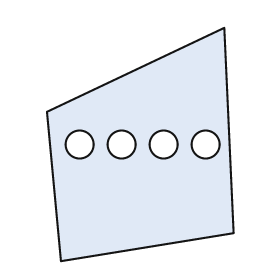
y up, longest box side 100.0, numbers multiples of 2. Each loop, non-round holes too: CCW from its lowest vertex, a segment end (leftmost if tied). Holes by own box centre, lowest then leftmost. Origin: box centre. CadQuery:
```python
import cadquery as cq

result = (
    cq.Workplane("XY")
    .moveTo(-34.0, -50.0)
    .lineTo(40.0, -38.0)
    .lineTo(36.0, 50.0)
    .lineTo(-40.0, 14.0)
    .close()
    .moveTo(-26.0, 0.0)
    .circle(6.0)
    .moveTo(-8.0, 0.0)
    .circle(6.0)
    .moveTo(10.0, 0.0)
    .circle(6.0)
    .moveTo(28.0, 0.0)
    .circle(6.0)
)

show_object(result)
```